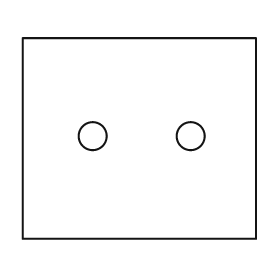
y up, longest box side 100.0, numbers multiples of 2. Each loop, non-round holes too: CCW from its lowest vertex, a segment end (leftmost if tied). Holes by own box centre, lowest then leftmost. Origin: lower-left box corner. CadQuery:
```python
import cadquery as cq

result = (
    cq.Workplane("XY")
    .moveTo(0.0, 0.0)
    .lineTo(100.0, 0.0)
    .lineTo(100.0, 86.0)
    .lineTo(0.0, 86.0)
    .close()
    .moveTo(30.0, 44.0)
    .circle(6.0)
    .moveTo(72.0, 44.0)
    .circle(6.0)
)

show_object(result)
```